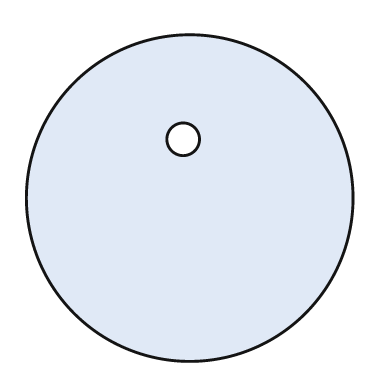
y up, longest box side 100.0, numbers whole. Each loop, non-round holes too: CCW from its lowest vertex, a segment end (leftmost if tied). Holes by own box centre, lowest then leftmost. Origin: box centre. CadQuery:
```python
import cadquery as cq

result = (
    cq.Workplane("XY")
    .moveTo(0.0, 0.0)
    .circle(50.0)
    .moveTo(-2.0, 18.0)
    .circle(5.0)
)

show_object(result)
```